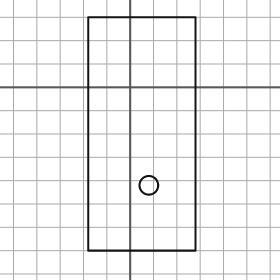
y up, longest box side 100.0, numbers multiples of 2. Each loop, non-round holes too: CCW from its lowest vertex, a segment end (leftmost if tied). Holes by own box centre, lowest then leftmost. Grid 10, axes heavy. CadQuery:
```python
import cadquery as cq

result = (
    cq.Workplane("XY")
    .moveTo(-18.0, -70.0)
    .lineTo(28.0, -70.0)
    .lineTo(28.0, 30.0)
    .lineTo(-18.0, 30.0)
    .close()
    .moveTo(8.0, -42.0)
    .circle(4.0)
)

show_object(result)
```